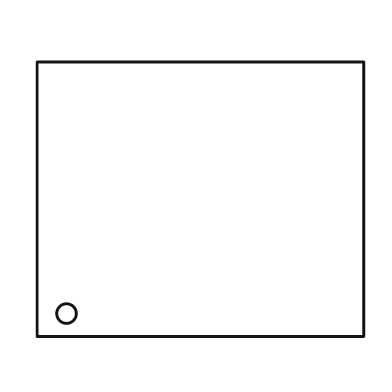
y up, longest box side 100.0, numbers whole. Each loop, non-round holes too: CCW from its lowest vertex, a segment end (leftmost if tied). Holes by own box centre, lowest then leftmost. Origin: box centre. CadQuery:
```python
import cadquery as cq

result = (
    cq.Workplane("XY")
    .moveTo(-50.0, -42.0)
    .lineTo(50.0, -42.0)
    .lineTo(50.0, 42.0)
    .lineTo(-50.0, 42.0)
    .close()
    .moveTo(-41.0, -35.0)
    .circle(3.0)
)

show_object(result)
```